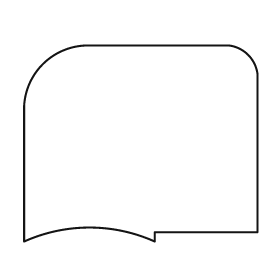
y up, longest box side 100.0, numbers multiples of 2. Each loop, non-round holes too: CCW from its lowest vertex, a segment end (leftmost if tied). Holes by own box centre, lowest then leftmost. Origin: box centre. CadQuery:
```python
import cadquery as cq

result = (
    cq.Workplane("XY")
    .moveTo(-50.0, -42.0)
    .threePointArc((-22.0, -36.0), (6.0, -42.0))
    .lineTo(6.0, -38.0)
    .lineTo(50.0, -38.0)
    .lineTo(50.0, 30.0)
    .threePointArc((46.0, 38.0), (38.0, 42.0))
    .lineTo(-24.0, 42.0)
    .threePointArc((-42.0, 34.0), (-50.0, 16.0))
    .close()
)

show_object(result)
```